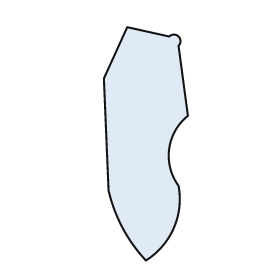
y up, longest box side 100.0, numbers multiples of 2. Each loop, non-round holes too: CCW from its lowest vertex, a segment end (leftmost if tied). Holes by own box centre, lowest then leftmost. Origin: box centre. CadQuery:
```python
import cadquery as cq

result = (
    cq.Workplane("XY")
    .moveTo(0.0, -50.0)
    .threePointArc((12.0, -36.0), (14.0, -18.0))
    .threePointArc((10.0, -2.0), (18.0, 12.0))
    .lineTo(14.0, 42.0)
    .threePointArc((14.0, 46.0), (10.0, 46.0))
    .lineTo(-8.0, 50.0)
    .lineTo(-18.0, 28.0)
    .lineTo(-16.0, -20.0)
    .threePointArc((-10.0, -36.0), (0.0, -50.0))
    .close()
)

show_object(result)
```